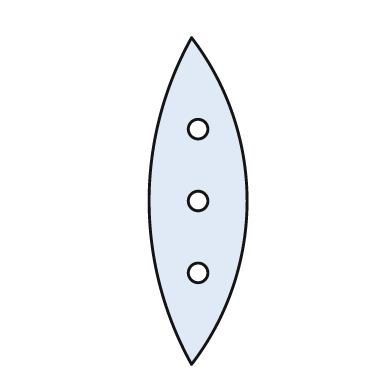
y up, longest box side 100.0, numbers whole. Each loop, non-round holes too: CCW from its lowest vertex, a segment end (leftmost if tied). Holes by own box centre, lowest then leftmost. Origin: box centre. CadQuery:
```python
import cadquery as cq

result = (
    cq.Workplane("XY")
    .moveTo(-2.0, -50.0)
    .threePointArc((15.0, 0.0), (-2.0, 50.0))
    .threePointArc((-15.0, 0.0), (-2.0, -50.0))
    .close()
    .moveTo(0.0, -22.0)
    .circle(3.0)
    .moveTo(0.0, 0.0)
    .circle(3.0)
    .moveTo(0.0, 22.0)
    .circle(3.0)
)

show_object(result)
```